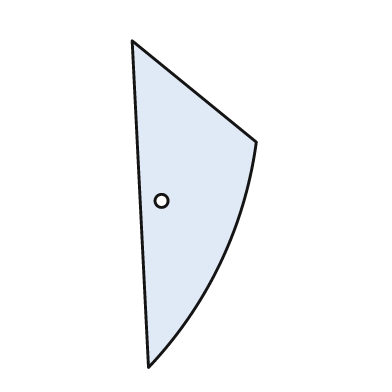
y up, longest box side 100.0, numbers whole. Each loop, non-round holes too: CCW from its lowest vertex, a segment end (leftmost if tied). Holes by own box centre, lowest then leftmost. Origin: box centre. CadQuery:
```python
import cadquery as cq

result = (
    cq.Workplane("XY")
    .moveTo(-14.0, -50.0)
    .threePointArc((8.0, -18.0), (19.0, 19.0))
    .lineTo(-19.0, 50.0)
    .close()
    .moveTo(-10.0, 1.0)
    .circle(2.0)
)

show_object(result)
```